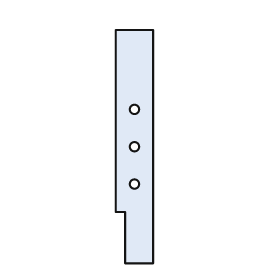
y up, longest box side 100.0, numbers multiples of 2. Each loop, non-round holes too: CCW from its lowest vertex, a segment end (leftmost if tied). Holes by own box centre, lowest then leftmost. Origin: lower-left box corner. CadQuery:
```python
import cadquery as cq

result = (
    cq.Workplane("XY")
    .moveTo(4.0, 0.0)
    .lineTo(16.0, 0.0)
    .lineTo(16.0, 100.0)
    .lineTo(0.0, 100.0)
    .lineTo(0.0, 22.0)
    .lineTo(4.0, 22.0)
    .close()
    .moveTo(8.0, 34.0)
    .circle(2.0)
    .moveTo(8.0, 50.0)
    .circle(2.0)
    .moveTo(8.0, 66.0)
    .circle(2.0)
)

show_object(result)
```